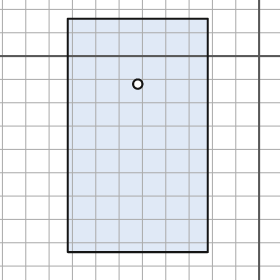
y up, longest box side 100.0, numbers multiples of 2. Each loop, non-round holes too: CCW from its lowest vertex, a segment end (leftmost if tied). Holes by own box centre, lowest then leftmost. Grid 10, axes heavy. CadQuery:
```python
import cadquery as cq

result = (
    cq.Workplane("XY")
    .moveTo(-82.0, -84.0)
    .lineTo(-22.0, -84.0)
    .lineTo(-22.0, 16.0)
    .lineTo(-82.0, 16.0)
    .close()
    .moveTo(-52.0, -12.0)
    .circle(2.0)
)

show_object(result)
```